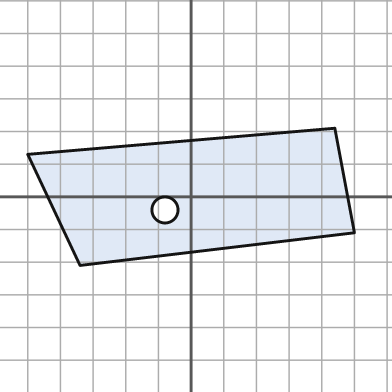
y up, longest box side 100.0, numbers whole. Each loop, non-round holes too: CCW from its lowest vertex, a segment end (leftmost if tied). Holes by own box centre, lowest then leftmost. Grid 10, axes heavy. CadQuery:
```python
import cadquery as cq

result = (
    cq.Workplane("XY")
    .moveTo(-34.0, -21.0)
    .lineTo(50.0, -11.0)
    .lineTo(44.0, 21.0)
    .lineTo(-50.0, 13.0)
    .close()
    .moveTo(-8.0, -4.0)
    .circle(4.0)
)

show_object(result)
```